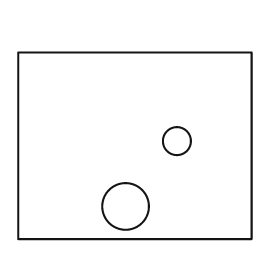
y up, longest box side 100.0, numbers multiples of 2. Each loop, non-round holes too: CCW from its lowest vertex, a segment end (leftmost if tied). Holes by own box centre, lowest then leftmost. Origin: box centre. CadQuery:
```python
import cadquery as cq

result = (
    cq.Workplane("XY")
    .moveTo(-50.0, -40.0)
    .lineTo(50.0, -40.0)
    .lineTo(50.0, 40.0)
    .lineTo(-50.0, 40.0)
    .close()
    .moveTo(-4.0, -26.0)
    .circle(10.0)
    .moveTo(18.0, 2.0)
    .circle(6.0)
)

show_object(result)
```